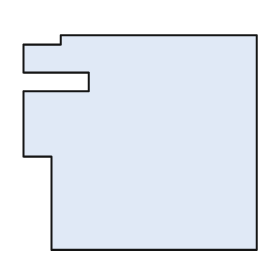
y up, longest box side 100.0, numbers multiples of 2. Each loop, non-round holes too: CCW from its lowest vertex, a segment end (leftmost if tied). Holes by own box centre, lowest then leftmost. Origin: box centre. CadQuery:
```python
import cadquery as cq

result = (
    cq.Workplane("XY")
    .moveTo(-38.0, -46.0)
    .lineTo(50.0, -46.0)
    .lineTo(50.0, 46.0)
    .lineTo(-34.0, 46.0)
    .lineTo(-34.0, 42.0)
    .lineTo(-50.0, 42.0)
    .lineTo(-50.0, 30.0)
    .lineTo(-22.0, 30.0)
    .lineTo(-22.0, 22.0)
    .lineTo(-50.0, 22.0)
    .lineTo(-50.0, -6.0)
    .lineTo(-38.0, -6.0)
    .close()
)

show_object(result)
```